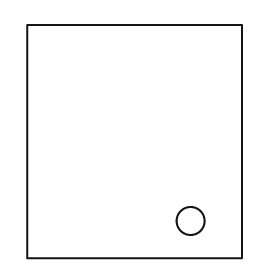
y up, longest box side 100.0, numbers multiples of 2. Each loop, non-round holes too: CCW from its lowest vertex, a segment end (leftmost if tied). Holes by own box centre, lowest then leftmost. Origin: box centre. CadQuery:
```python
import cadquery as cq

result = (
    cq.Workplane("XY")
    .moveTo(-46.0, -50.0)
    .lineTo(46.0, -50.0)
    .lineTo(46.0, 50.0)
    .lineTo(-46.0, 50.0)
    .close()
    .moveTo(24.0, -34.0)
    .circle(6.0)
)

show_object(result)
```